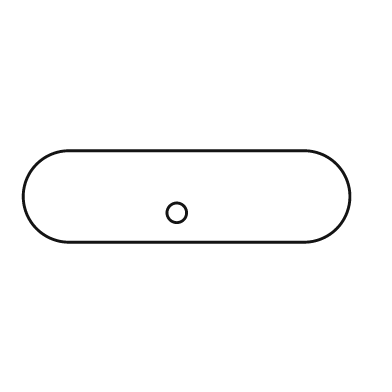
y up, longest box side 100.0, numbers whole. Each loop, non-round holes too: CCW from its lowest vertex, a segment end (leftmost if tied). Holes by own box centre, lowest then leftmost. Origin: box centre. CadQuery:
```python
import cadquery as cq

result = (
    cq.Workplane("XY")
    .moveTo(-36.0, -14.0)
    .lineTo(36.0, -14.0)
    .threePointArc((50.0, 0.0), (36.0, 14.0))
    .lineTo(-36.0, 14.0)
    .threePointArc((-50.0, 0.0), (-36.0, -14.0))
    .close()
    .moveTo(-3.0, -5.0)
    .circle(3.0)
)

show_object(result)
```